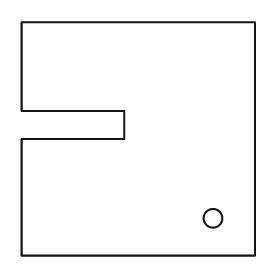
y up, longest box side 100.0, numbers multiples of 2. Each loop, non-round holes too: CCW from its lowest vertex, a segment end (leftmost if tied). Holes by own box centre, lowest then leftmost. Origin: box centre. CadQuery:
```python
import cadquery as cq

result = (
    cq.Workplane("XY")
    .moveTo(-50.0, -50.0)
    .lineTo(50.0, -50.0)
    .lineTo(50.0, 50.0)
    .lineTo(-50.0, 50.0)
    .lineTo(-50.0, 12.0)
    .lineTo(-6.0, 12.0)
    .lineTo(-6.0, 0.0)
    .lineTo(-50.0, 0.0)
    .close()
    .moveTo(32.0, -34.0)
    .circle(4.0)
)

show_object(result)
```